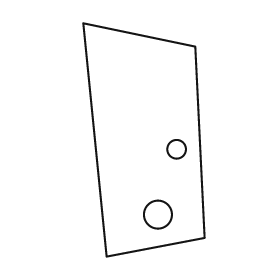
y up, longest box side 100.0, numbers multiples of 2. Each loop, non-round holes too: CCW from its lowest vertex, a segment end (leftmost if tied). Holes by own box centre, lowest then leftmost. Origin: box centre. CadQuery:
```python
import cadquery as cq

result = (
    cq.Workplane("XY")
    .moveTo(-16.0, -50.0)
    .lineTo(26.0, -42.0)
    .lineTo(22.0, 40.0)
    .lineTo(-26.0, 50.0)
    .close()
    .moveTo(6.0, -32.0)
    .circle(6.0)
    .moveTo(14.0, -4.0)
    .circle(4.0)
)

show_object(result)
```